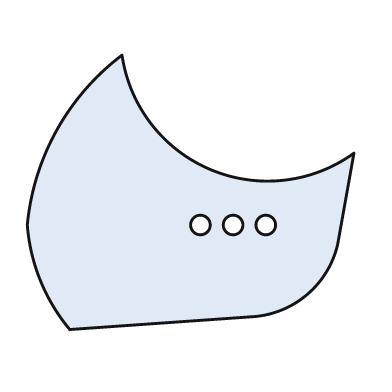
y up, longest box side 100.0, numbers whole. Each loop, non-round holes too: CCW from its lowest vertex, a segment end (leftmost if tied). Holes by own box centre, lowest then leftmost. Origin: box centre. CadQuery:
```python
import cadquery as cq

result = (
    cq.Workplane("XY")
    .moveTo(-37.0, -42.0)
    .lineTo(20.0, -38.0)
    .threePointArc((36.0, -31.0), (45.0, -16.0))
    .lineTo(50.0, 12.0)
    .threePointArc((6.0, 7.0), (-21.0, 42.0))
    .threePointArc((-41.0, 19.0), (-50.0, -10.0))
    .threePointArc((-46.0, -27.0), (-37.0, -42.0))
    .close()
    .moveTo(3.0, -10.0)
    .circle(3.0)
    .moveTo(13.0, -10.0)
    .circle(3.0)
    .moveTo(23.0, -10.0)
    .circle(3.0)
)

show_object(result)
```